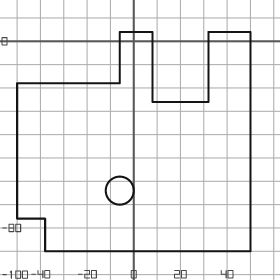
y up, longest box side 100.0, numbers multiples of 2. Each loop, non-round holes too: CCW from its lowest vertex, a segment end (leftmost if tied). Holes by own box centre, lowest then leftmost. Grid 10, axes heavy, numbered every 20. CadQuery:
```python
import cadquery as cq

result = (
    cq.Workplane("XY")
    .moveTo(-38.0, -90.0)
    .lineTo(50.0, -90.0)
    .lineTo(50.0, 4.0)
    .lineTo(32.0, 4.0)
    .lineTo(32.0, -26.0)
    .lineTo(8.0, -26.0)
    .lineTo(8.0, 4.0)
    .lineTo(-6.0, 4.0)
    .lineTo(-6.0, -18.0)
    .lineTo(-50.0, -18.0)
    .lineTo(-50.0, -76.0)
    .lineTo(-38.0, -76.0)
    .close()
    .moveTo(-6.0, -64.0)
    .circle(6.0)
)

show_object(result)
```